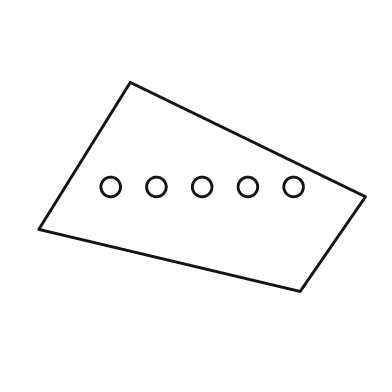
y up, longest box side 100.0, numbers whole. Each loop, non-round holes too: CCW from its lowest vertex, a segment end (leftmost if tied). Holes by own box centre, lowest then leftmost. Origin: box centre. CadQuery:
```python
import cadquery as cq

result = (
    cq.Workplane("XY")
    .moveTo(30.0, -32.0)
    .lineTo(50.0, -3.0)
    .lineTo(-22.0, 32.0)
    .lineTo(-50.0, -13.0)
    .close()
    .moveTo(-28.0, 0.0)
    .circle(3.0)
    .moveTo(-14.0, 0.0)
    .circle(3.0)
    .moveTo(0.0, 0.0)
    .circle(3.0)
    .moveTo(14.0, 0.0)
    .circle(3.0)
    .moveTo(28.0, 0.0)
    .circle(3.0)
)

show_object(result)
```